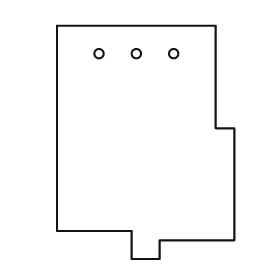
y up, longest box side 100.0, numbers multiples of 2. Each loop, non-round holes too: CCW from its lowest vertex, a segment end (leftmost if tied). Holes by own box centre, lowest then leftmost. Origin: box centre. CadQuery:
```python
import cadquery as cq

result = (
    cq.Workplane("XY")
    .moveTo(-6.0, -50.0)
    .lineTo(6.0, -50.0)
    .lineTo(6.0, -42.0)
    .lineTo(38.0, -42.0)
    .lineTo(38.0, 6.0)
    .lineTo(30.0, 6.0)
    .lineTo(30.0, 50.0)
    .lineTo(-38.0, 50.0)
    .lineTo(-38.0, -38.0)
    .lineTo(-6.0, -38.0)
    .close()
    .moveTo(-20.0, 38.0)
    .circle(2.0)
    .moveTo(-4.0, 38.0)
    .circle(2.0)
    .moveTo(12.0, 38.0)
    .circle(2.0)
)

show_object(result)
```